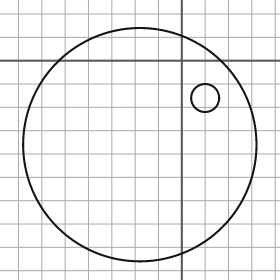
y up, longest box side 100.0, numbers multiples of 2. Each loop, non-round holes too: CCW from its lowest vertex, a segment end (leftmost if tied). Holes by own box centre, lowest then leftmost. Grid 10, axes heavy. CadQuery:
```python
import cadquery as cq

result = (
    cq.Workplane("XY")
    .moveTo(-18.0, -36.0)
    .circle(50.0)
    .moveTo(10.0, -16.0)
    .circle(6.0)
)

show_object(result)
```